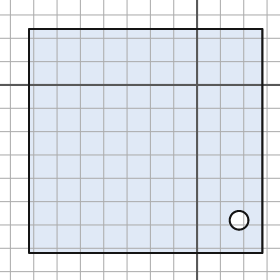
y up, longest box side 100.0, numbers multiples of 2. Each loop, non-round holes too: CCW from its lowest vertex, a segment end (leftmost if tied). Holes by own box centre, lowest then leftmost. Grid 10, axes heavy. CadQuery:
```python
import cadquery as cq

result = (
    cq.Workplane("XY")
    .moveTo(-72.0, -72.0)
    .lineTo(28.0, -72.0)
    .lineTo(28.0, 24.0)
    .lineTo(-72.0, 24.0)
    .close()
    .moveTo(18.0, -58.0)
    .circle(4.0)
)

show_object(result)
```